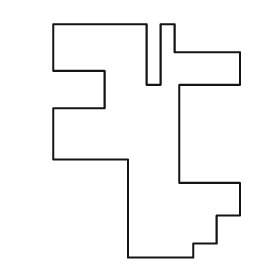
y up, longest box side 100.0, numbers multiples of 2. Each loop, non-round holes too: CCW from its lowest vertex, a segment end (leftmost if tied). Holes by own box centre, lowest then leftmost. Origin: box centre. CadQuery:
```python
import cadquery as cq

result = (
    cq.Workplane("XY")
    .moveTo(-8.0, -50.0)
    .lineTo(20.0, -50.0)
    .lineTo(20.0, -44.0)
    .lineTo(30.0, -44.0)
    .lineTo(30.0, -32.0)
    .lineTo(40.0, -32.0)
    .lineTo(40.0, -18.0)
    .lineTo(14.0, -18.0)
    .lineTo(14.0, 24.0)
    .lineTo(40.0, 24.0)
    .lineTo(40.0, 38.0)
    .lineTo(12.0, 38.0)
    .lineTo(12.0, 50.0)
    .lineTo(6.0, 50.0)
    .lineTo(6.0, 24.0)
    .lineTo(0.0, 24.0)
    .lineTo(0.0, 50.0)
    .lineTo(-40.0, 50.0)
    .lineTo(-40.0, 30.0)
    .lineTo(-18.0, 30.0)
    .lineTo(-18.0, 14.0)
    .lineTo(-40.0, 14.0)
    .lineTo(-40.0, -8.0)
    .lineTo(-8.0, -8.0)
    .close()
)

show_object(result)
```